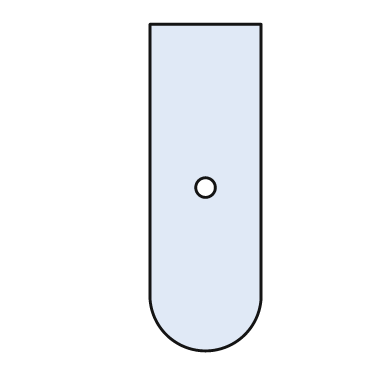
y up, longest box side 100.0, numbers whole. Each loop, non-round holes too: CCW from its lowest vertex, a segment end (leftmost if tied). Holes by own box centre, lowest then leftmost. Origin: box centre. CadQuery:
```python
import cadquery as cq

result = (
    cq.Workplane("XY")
    .moveTo(-17.0, -34.0)
    .threePointArc((0.0, -50.0), (17.0, -34.0))
    .lineTo(17.0, 50.0)
    .lineTo(-17.0, 50.0)
    .close()
    .moveTo(0.0, 0.0)
    .circle(3.0)
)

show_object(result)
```